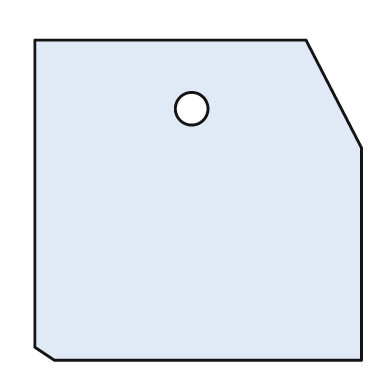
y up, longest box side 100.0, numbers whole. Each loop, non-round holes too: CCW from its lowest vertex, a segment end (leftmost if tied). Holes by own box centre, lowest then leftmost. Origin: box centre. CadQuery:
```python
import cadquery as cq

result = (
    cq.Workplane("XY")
    .moveTo(-44.0, -49.0)
    .lineTo(50.0, -49.0)
    .lineTo(50.0, 16.0)
    .lineTo(33.0, 49.0)
    .lineTo(-50.0, 49.0)
    .lineTo(-50.0, -45.0)
    .close()
    .moveTo(-2.0, 28.0)
    .circle(5.0)
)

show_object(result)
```